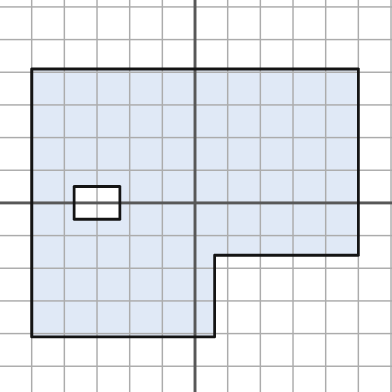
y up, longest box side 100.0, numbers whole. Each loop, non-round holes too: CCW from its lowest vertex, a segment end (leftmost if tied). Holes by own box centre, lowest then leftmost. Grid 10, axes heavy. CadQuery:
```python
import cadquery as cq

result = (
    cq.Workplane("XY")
    .moveTo(-50.0, -41.0)
    .lineTo(6.0, -41.0)
    .lineTo(6.0, -16.0)
    .lineTo(50.0, -16.0)
    .lineTo(50.0, 41.0)
    .lineTo(-50.0, 41.0)
    .close()
    .moveTo(-37.0, -5.0)
    .lineTo(-23.0, -5.0)
    .lineTo(-23.0, 5.0)
    .lineTo(-37.0, 5.0)
    .close()
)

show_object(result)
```